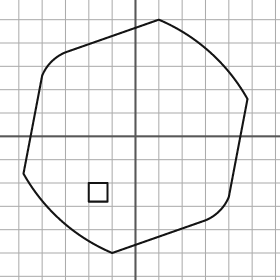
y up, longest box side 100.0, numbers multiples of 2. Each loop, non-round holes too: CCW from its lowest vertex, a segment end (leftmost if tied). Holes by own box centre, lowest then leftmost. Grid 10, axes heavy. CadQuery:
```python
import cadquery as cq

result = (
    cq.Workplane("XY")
    .moveTo(-10.0, -50.0)
    .lineTo(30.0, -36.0)
    .threePointArc((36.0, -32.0), (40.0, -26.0))
    .lineTo(48.0, 16.0)
    .threePointArc((32.0, 36.0), (10.0, 50.0))
    .lineTo(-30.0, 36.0)
    .threePointArc((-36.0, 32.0), (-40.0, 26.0))
    .lineTo(-48.0, -16.0)
    .threePointArc((-32.0, -36.0), (-10.0, -50.0))
    .close()
    .moveTo(-20.0, -28.0)
    .lineTo(-12.0, -28.0)
    .lineTo(-12.0, -20.0)
    .lineTo(-20.0, -20.0)
    .close()
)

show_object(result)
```